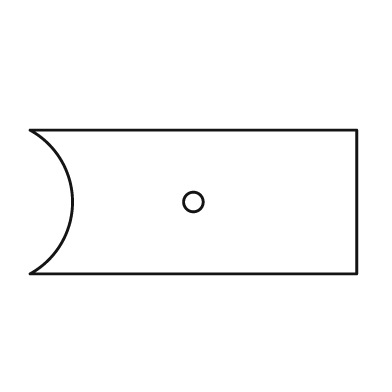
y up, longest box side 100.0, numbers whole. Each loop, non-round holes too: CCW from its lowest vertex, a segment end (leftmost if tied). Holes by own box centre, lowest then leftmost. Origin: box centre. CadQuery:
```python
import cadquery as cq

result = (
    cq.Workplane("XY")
    .moveTo(-50.0, -22.0)
    .lineTo(50.0, -22.0)
    .lineTo(50.0, 22.0)
    .lineTo(-50.0, 22.0)
    .threePointArc((-37.0, 0.0), (-50.0, -22.0))
    .close()
    .moveTo(0.0, 0.0)
    .circle(3.0)
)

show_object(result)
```